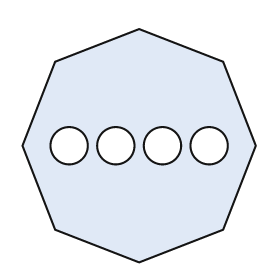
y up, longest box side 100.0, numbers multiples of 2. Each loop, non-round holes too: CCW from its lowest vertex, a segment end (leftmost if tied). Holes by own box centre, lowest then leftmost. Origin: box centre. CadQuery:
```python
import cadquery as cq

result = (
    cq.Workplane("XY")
    .moveTo(0.0, -50.0)
    .lineTo(36.0, -36.0)
    .lineTo(50.0, 0.0)
    .lineTo(36.0, 36.0)
    .lineTo(0.0, 50.0)
    .lineTo(-36.0, 36.0)
    .lineTo(-50.0, 0.0)
    .lineTo(-36.0, -36.0)
    .close()
    .moveTo(-30.0, 0.0)
    .circle(8.0)
    .moveTo(-10.0, 0.0)
    .circle(8.0)
    .moveTo(10.0, 0.0)
    .circle(8.0)
    .moveTo(30.0, 0.0)
    .circle(8.0)
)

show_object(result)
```